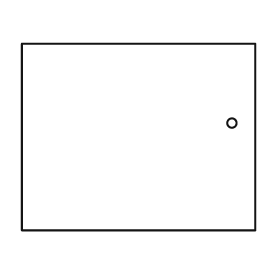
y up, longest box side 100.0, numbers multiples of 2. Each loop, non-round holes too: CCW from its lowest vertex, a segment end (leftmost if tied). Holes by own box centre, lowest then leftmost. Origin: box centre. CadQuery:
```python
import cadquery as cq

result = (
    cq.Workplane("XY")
    .moveTo(-50.0, -40.0)
    .lineTo(50.0, -40.0)
    .lineTo(50.0, 40.0)
    .lineTo(-50.0, 40.0)
    .close()
    .moveTo(40.0, 6.0)
    .circle(2.0)
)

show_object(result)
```